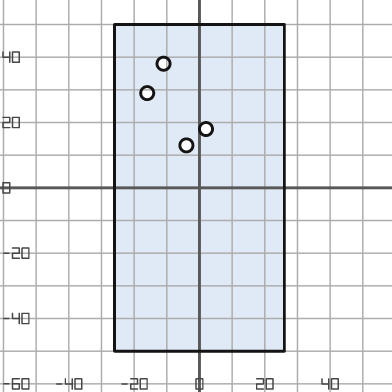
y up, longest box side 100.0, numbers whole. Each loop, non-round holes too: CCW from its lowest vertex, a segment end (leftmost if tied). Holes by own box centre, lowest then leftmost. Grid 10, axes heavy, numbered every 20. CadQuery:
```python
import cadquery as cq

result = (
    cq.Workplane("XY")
    .moveTo(-26.0, -50.0)
    .lineTo(26.0, -50.0)
    .lineTo(26.0, 50.0)
    .lineTo(-26.0, 50.0)
    .close()
    .moveTo(-4.0, 13.0)
    .circle(2.0)
    .moveTo(2.0, 18.0)
    .circle(2.0)
    .moveTo(-16.0, 29.0)
    .circle(2.0)
    .moveTo(-11.0, 38.0)
    .circle(2.0)
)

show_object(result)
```